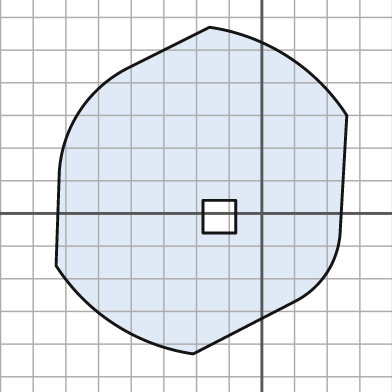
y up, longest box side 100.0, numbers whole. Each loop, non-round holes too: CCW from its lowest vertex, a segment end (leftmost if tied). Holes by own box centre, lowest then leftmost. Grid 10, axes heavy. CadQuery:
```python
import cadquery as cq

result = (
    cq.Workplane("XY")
    .moveTo(-21.0, -43.0)
    .lineTo(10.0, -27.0)
    .threePointArc((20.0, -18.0), (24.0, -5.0))
    .lineTo(26.0, 30.0)
    .threePointArc((8.0, 48.0), (-16.0, 57.0))
    .lineTo(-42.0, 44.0)
    .threePointArc((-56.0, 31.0), (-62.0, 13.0))
    .lineTo(-63.0, -16.0)
    .threePointArc((-45.0, -34.0), (-21.0, -43.0))
    .close()
    .moveTo(-18.0, -6.0)
    .lineTo(-8.0, -6.0)
    .lineTo(-8.0, 4.0)
    .lineTo(-18.0, 4.0)
    .close()
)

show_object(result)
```